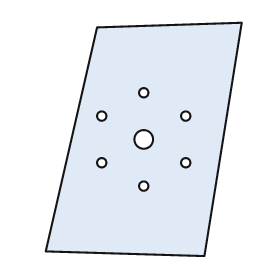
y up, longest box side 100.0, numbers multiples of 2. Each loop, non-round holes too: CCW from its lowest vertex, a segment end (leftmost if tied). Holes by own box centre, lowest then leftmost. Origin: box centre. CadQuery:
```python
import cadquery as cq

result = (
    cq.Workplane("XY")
    .moveTo(26.0, -50.0)
    .lineTo(42.0, 50.0)
    .lineTo(-20.0, 48.0)
    .lineTo(-42.0, -48.0)
    .close()
    .moveTo(0.0, -20.0)
    .circle(2.0)
    .moveTo(-18.0, -10.0)
    .circle(2.0)
    .moveTo(18.0, -10.0)
    .circle(2.0)
    .moveTo(0.0, 0.0)
    .circle(4.0)
    .moveTo(-18.0, 10.0)
    .circle(2.0)
    .moveTo(18.0, 10.0)
    .circle(2.0)
    .moveTo(0.0, 20.0)
    .circle(2.0)
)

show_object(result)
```